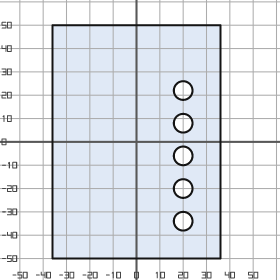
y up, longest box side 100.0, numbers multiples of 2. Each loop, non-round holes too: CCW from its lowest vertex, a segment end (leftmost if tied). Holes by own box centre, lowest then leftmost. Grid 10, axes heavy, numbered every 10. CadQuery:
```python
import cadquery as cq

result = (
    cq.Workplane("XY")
    .moveTo(-36.0, -50.0)
    .lineTo(36.0, -50.0)
    .lineTo(36.0, 50.0)
    .lineTo(-36.0, 50.0)
    .close()
    .moveTo(20.0, -34.0)
    .circle(4.0)
    .moveTo(20.0, -20.0)
    .circle(4.0)
    .moveTo(20.0, -6.0)
    .circle(4.0)
    .moveTo(20.0, 8.0)
    .circle(4.0)
    .moveTo(20.0, 22.0)
    .circle(4.0)
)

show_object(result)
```